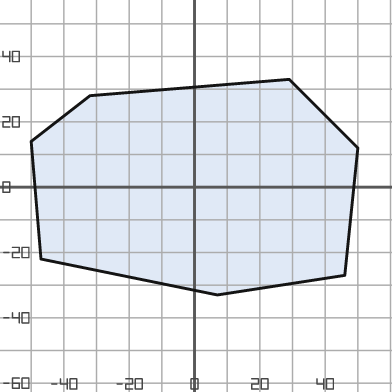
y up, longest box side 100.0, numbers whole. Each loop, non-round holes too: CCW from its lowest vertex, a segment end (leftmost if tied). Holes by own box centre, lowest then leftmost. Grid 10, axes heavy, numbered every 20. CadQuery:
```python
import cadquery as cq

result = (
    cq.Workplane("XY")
    .moveTo(7.0, -33.0)
    .lineTo(46.0, -27.0)
    .lineTo(50.0, 12.0)
    .lineTo(29.0, 33.0)
    .lineTo(-32.0, 28.0)
    .lineTo(-50.0, 14.0)
    .lineTo(-47.0, -22.0)
    .close()
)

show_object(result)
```